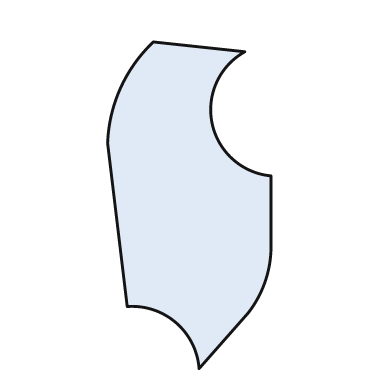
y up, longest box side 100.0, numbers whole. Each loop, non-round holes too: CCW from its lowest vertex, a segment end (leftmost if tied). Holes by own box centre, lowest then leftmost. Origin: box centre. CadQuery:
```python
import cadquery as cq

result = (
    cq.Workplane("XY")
    .moveTo(3.0, -50.0)
    .lineTo(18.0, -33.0)
    .threePointArc((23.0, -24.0), (25.0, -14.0))
    .lineTo(25.0, 9.0)
    .threePointArc((7.0, 25.0), (17.0, 47.0))
    .lineTo(-11.0, 50.0)
    .threePointArc((-21.0, 36.0), (-25.0, 19.0))
    .lineTo(-19.0, -31.0)
    .threePointArc((-4.0, -36.0), (3.0, -50.0))
    .close()
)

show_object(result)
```